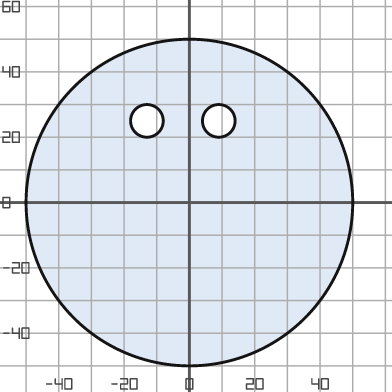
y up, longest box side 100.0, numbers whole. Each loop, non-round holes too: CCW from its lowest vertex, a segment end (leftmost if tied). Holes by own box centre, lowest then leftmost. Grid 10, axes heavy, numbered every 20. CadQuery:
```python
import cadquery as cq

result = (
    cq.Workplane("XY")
    .moveTo(0.0, 0.0)
    .circle(50.0)
    .moveTo(-13.0, 25.0)
    .circle(5.0)
    .moveTo(9.0, 25.0)
    .circle(5.0)
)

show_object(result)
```